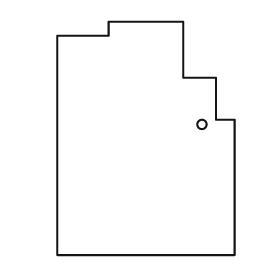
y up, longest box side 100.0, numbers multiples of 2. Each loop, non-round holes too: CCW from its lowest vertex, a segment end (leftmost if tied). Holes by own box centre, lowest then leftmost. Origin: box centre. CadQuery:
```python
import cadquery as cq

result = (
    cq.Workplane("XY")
    .moveTo(-38.0, -50.0)
    .lineTo(38.0, -50.0)
    .lineTo(38.0, 8.0)
    .lineTo(30.0, 8.0)
    .lineTo(30.0, 26.0)
    .lineTo(16.0, 26.0)
    .lineTo(16.0, 50.0)
    .lineTo(-16.0, 50.0)
    .lineTo(-16.0, 44.0)
    .lineTo(-38.0, 44.0)
    .close()
    .moveTo(24.0, 6.0)
    .circle(2.0)
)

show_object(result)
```